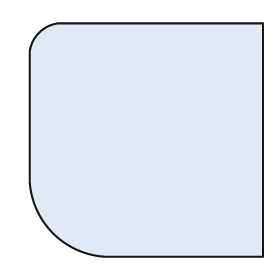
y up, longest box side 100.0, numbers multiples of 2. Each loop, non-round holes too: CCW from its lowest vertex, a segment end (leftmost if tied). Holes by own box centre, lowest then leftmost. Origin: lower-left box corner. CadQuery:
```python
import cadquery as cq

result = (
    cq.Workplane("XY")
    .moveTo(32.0, 0.0)
    .lineTo(100.0, 0.0)
    .lineTo(100.0, 100.0)
    .lineTo(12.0, 100.0)
    .threePointArc((4.0, 96.0), (0.0, 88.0))
    .lineTo(0.0, 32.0)
    .threePointArc((10.0, 10.0), (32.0, 0.0))
    .close()
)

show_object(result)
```